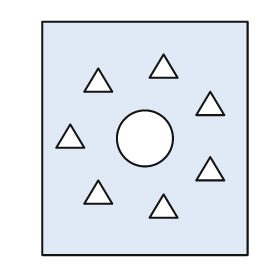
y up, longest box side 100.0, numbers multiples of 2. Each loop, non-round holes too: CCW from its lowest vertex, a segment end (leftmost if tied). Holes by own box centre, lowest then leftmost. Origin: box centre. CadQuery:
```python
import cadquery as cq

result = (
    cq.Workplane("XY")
    .moveTo(-44.0, -50.0)
    .lineTo(44.0, -50.0)
    .lineTo(44.0, 50.0)
    .lineTo(-44.0, 50.0)
    .close()
    .moveTo(2.0, -34.0)
    .lineTo(14.0, -34.0)
    .lineTo(8.0, -24.0)
    .close()
    .moveTo(-26.0, -28.0)
    .lineTo(-14.0, -28.0)
    .lineTo(-20.0, -18.0)
    .close()
    .moveTo(22.0, -18.0)
    .lineTo(34.0, -18.0)
    .lineTo(28.0, -8.0)
    .close()
    .moveTo(0.0, 0.0)
    .circle(12.0)
    .moveTo(-38.0, -4.0)
    .lineTo(-26.0, -4.0)
    .lineTo(-32.0, 6.0)
    .close()
    .moveTo(22.0, 10.0)
    .lineTo(34.0, 10.0)
    .lineTo(28.0, 20.0)
    .close()
    .moveTo(-26.0, 20.0)
    .lineTo(-14.0, 20.0)
    .lineTo(-20.0, 30.0)
    .close()
    .moveTo(2.0, 26.0)
    .lineTo(14.0, 26.0)
    .lineTo(8.0, 36.0)
    .close()
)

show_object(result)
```